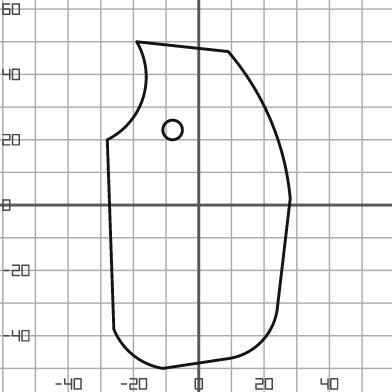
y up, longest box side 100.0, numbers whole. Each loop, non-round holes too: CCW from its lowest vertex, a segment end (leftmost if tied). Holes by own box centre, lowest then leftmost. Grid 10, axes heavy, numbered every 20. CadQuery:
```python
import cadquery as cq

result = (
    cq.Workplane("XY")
    .moveTo(-11.0, -50.0)
    .lineTo(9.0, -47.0)
    .threePointArc((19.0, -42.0), (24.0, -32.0))
    .lineTo(28.0, 2.0)
    .threePointArc((22.0, 26.0), (9.0, 47.0))
    .lineTo(-19.0, 50.0)
    .threePointArc((-17.0, 33.0), (-28.0, 20.0))
    .lineTo(-26.0, -38.0)
    .threePointArc((-20.0, -46.0), (-11.0, -50.0))
    .close()
    .moveTo(-8.0, 23.0)
    .circle(3.0)
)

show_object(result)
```